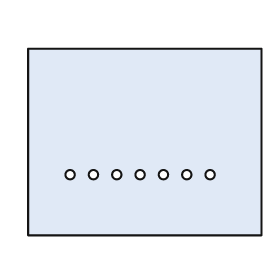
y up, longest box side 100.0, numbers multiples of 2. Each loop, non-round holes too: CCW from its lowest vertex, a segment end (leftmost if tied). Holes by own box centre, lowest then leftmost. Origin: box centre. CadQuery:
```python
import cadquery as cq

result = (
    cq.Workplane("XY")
    .moveTo(-50.0, -40.0)
    .lineTo(50.0, -40.0)
    .lineTo(50.0, 40.0)
    .lineTo(-50.0, 40.0)
    .close()
    .moveTo(-32.0, -14.0)
    .circle(2.0)
    .moveTo(-22.0, -14.0)
    .circle(2.0)
    .moveTo(-12.0, -14.0)
    .circle(2.0)
    .moveTo(-2.0, -14.0)
    .circle(2.0)
    .moveTo(8.0, -14.0)
    .circle(2.0)
    .moveTo(18.0, -14.0)
    .circle(2.0)
    .moveTo(28.0, -14.0)
    .circle(2.0)
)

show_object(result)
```